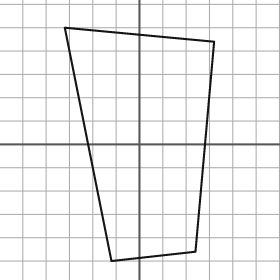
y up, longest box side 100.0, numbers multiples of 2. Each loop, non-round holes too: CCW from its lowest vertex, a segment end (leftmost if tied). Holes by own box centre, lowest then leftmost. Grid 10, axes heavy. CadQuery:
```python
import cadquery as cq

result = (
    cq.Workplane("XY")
    .moveTo(-12.0, -50.0)
    .lineTo(24.0, -46.0)
    .lineTo(32.0, 44.0)
    .lineTo(-32.0, 50.0)
    .close()
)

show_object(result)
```